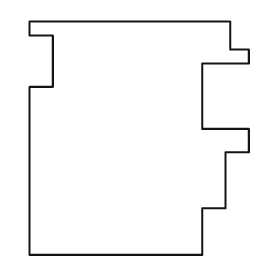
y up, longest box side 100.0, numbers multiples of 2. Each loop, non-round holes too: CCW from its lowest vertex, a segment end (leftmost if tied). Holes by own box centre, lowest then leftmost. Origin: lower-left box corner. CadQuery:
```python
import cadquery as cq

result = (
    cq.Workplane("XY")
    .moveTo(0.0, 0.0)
    .lineTo(74.0, 0.0)
    .lineTo(74.0, 20.0)
    .lineTo(84.0, 20.0)
    .lineTo(84.0, 44.0)
    .lineTo(94.0, 44.0)
    .lineTo(94.0, 54.0)
    .lineTo(74.0, 54.0)
    .lineTo(74.0, 82.0)
    .lineTo(94.0, 82.0)
    .lineTo(94.0, 88.0)
    .lineTo(86.0, 88.0)
    .lineTo(86.0, 100.0)
    .lineTo(0.0, 100.0)
    .lineTo(0.0, 94.0)
    .lineTo(10.0, 94.0)
    .lineTo(10.0, 72.0)
    .lineTo(0.0, 72.0)
    .close()
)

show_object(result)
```